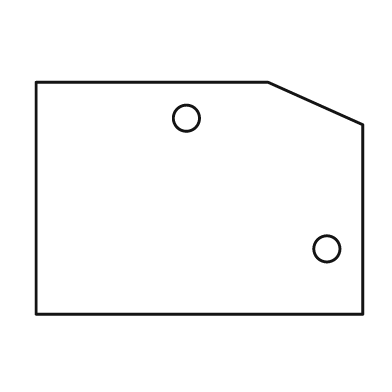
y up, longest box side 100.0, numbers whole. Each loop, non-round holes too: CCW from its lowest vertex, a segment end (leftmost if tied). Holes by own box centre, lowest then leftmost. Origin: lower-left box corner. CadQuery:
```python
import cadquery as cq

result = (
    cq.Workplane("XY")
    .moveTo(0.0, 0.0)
    .lineTo(100.0, 0.0)
    .lineTo(100.0, 58.0)
    .lineTo(71.0, 71.0)
    .lineTo(0.0, 71.0)
    .close()
    .moveTo(89.0, 20.0)
    .circle(4.0)
    .moveTo(46.0, 60.0)
    .circle(4.0)
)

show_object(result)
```